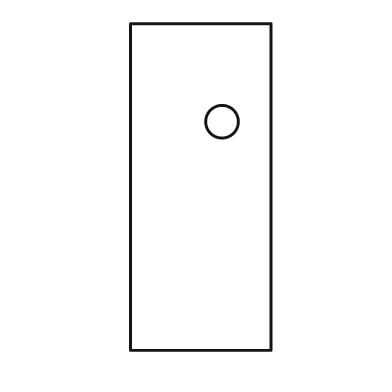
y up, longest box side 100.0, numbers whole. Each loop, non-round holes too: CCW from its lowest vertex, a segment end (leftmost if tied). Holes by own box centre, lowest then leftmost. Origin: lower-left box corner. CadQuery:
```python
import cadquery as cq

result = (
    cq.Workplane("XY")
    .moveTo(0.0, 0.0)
    .lineTo(43.0, 0.0)
    .lineTo(43.0, 100.0)
    .lineTo(0.0, 100.0)
    .close()
    .moveTo(28.0, 70.0)
    .circle(5.0)
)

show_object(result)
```